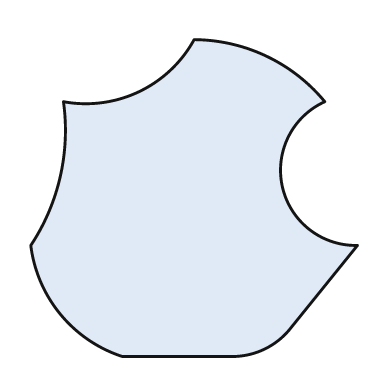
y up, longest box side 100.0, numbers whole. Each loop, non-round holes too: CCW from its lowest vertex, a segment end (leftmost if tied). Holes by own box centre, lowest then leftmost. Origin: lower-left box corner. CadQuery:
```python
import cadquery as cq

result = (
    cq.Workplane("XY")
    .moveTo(28.0, 0.0)
    .lineTo(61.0, 0.0)
    .threePointArc((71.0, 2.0), (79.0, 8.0))
    .lineTo(100.0, 34.0)
    .threePointArc((77.0, 52.0), (90.0, 78.0))
    .threePointArc((72.0, 92.0), (50.0, 97.0))
    .threePointArc((33.0, 81.0), (10.0, 78.0))
    .threePointArc((9.0, 55.0), (0.0, 34.0))
    .threePointArc((9.0, 13.0), (28.0, 0.0))
    .close()
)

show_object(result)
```